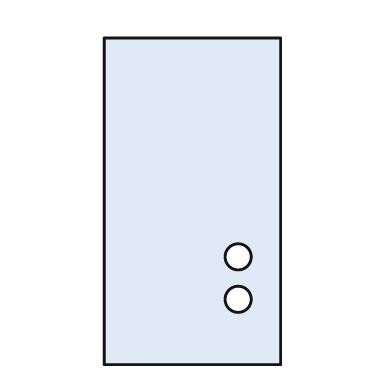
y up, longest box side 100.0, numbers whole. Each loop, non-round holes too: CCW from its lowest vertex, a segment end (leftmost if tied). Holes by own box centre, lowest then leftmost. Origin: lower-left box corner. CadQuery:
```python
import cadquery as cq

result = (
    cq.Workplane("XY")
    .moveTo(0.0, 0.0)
    .lineTo(54.0, 0.0)
    .lineTo(54.0, 100.0)
    .lineTo(0.0, 100.0)
    .close()
    .moveTo(41.0, 20.0)
    .circle(4.0)
    .moveTo(41.0, 33.0)
    .circle(4.0)
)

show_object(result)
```